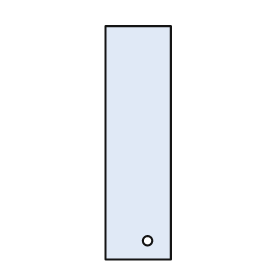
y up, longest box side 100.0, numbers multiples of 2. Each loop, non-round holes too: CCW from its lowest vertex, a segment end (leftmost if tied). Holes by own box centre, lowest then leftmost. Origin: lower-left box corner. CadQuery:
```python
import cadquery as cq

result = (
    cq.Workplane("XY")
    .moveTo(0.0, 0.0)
    .lineTo(28.0, 0.0)
    .lineTo(28.0, 100.0)
    .lineTo(0.0, 100.0)
    .close()
    .moveTo(18.0, 8.0)
    .circle(2.0)
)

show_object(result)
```